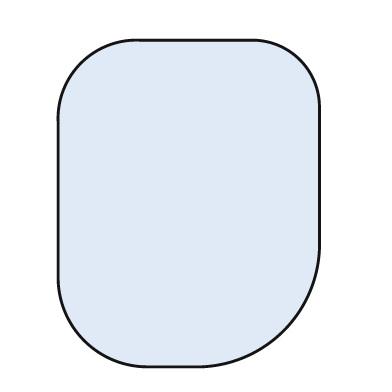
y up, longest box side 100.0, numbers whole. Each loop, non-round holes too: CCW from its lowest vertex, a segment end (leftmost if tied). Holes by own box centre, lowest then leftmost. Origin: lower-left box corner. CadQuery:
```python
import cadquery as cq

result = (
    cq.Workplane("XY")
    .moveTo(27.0, 0.0)
    .lineTo(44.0, 0.0)
    .threePointArc((69.0, 11.0), (80.0, 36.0))
    .lineTo(80.0, 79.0)
    .threePointArc((74.0, 94.0), (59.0, 100.0))
    .lineTo(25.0, 100.0)
    .threePointArc((7.0, 93.0), (0.0, 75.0))
    .lineTo(0.0, 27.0)
    .threePointArc((8.0, 8.0), (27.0, 0.0))
    .close()
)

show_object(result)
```